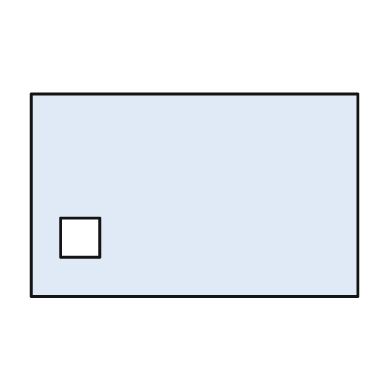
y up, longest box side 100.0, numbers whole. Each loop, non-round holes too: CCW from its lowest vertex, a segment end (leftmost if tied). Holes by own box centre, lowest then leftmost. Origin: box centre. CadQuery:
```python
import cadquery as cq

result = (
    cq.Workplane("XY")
    .moveTo(-50.0, -31.0)
    .lineTo(50.0, -31.0)
    .lineTo(50.0, 31.0)
    .lineTo(-50.0, 31.0)
    .close()
    .moveTo(-41.0, -19.0)
    .lineTo(-29.0, -19.0)
    .lineTo(-29.0, -7.0)
    .lineTo(-41.0, -7.0)
    .close()
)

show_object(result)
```